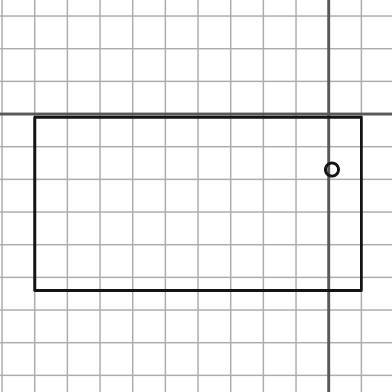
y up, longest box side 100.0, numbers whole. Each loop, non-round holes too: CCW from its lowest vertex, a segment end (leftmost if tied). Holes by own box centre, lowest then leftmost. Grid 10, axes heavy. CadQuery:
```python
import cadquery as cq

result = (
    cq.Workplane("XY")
    .moveTo(-90.0, -54.0)
    .lineTo(10.0, -54.0)
    .lineTo(10.0, -1.0)
    .lineTo(-90.0, -1.0)
    .close()
    .moveTo(1.0, -17.0)
    .circle(2.0)
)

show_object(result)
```